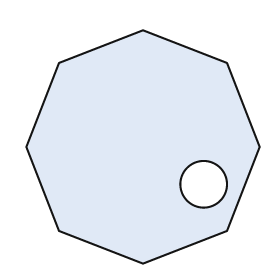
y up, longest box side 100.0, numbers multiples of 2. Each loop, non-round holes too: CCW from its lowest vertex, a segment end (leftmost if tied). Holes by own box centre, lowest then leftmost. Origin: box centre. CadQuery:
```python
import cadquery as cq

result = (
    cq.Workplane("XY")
    .moveTo(0.0, -50.0)
    .lineTo(36.0, -36.0)
    .lineTo(50.0, 0.0)
    .lineTo(36.0, 36.0)
    .lineTo(0.0, 50.0)
    .lineTo(-36.0, 36.0)
    .lineTo(-50.0, 0.0)
    .lineTo(-36.0, -36.0)
    .close()
    .moveTo(26.0, -16.0)
    .circle(10.0)
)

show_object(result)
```